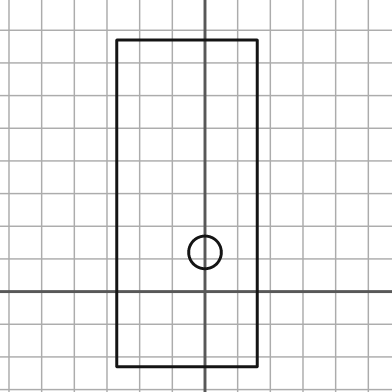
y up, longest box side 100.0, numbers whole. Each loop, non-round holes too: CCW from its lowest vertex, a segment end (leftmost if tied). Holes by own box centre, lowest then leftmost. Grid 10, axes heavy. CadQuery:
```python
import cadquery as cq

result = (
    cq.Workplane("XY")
    .moveTo(-27.0, -23.0)
    .lineTo(16.0, -23.0)
    .lineTo(16.0, 77.0)
    .lineTo(-27.0, 77.0)
    .close()
    .moveTo(0.0, 12.0)
    .circle(5.0)
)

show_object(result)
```